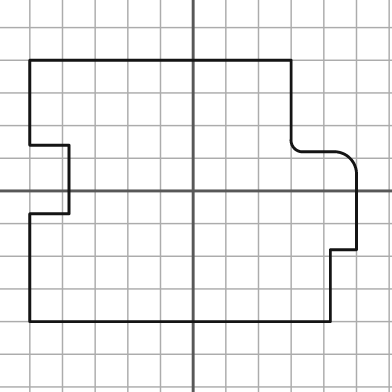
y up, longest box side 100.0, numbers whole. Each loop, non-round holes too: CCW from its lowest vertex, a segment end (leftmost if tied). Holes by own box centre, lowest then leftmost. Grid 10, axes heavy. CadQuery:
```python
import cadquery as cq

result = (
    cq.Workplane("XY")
    .moveTo(-50.0, -40.0)
    .lineTo(42.0, -40.0)
    .lineTo(42.0, -18.0)
    .lineTo(50.0, -18.0)
    .lineTo(50.0, 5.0)
    .threePointArc((48.0, 10.0), (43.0, 12.0))
    .lineTo(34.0, 12.0)
    .threePointArc((31.0, 13.0), (30.0, 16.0))
    .lineTo(30.0, 40.0)
    .lineTo(-50.0, 40.0)
    .lineTo(-50.0, 14.0)
    .lineTo(-38.0, 14.0)
    .lineTo(-38.0, -7.0)
    .lineTo(-50.0, -7.0)
    .close()
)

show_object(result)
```